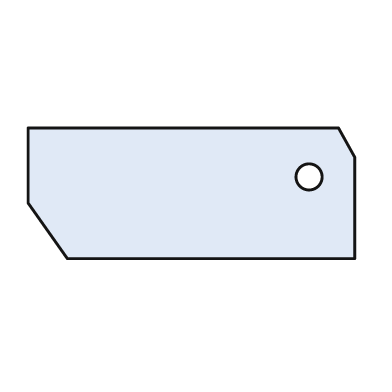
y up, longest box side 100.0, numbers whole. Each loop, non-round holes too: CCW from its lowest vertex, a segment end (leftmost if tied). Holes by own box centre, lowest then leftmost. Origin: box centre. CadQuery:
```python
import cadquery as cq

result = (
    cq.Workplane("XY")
    .moveTo(-38.0, -20.0)
    .lineTo(50.0, -20.0)
    .lineTo(50.0, 11.0)
    .lineTo(45.0, 20.0)
    .lineTo(-50.0, 20.0)
    .lineTo(-50.0, -3.0)
    .close()
    .moveTo(36.0, 5.0)
    .circle(4.0)
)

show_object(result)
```